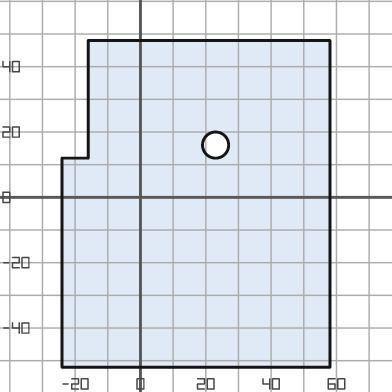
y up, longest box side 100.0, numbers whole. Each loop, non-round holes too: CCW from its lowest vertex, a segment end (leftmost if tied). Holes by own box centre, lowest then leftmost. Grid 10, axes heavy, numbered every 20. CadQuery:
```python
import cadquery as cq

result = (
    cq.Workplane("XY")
    .moveTo(-24.0, -52.0)
    .lineTo(58.0, -52.0)
    .lineTo(58.0, 48.0)
    .lineTo(-16.0, 48.0)
    .lineTo(-16.0, 12.0)
    .lineTo(-24.0, 12.0)
    .close()
    .moveTo(23.0, 16.0)
    .circle(4.0)
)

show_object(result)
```